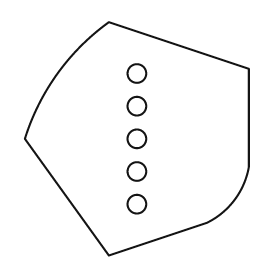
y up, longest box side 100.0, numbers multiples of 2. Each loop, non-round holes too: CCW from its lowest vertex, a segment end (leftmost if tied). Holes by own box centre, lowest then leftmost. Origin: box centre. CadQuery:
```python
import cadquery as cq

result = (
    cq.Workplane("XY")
    .moveTo(-12.0, -50.0)
    .lineTo(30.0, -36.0)
    .threePointArc((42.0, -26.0), (48.0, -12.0))
    .lineTo(48.0, 30.0)
    .lineTo(-12.0, 50.0)
    .threePointArc((-34.0, 28.0), (-48.0, 0.0))
    .close()
    .moveTo(0.0, -28.0)
    .circle(4.0)
    .moveTo(0.0, -14.0)
    .circle(4.0)
    .moveTo(0.0, 0.0)
    .circle(4.0)
    .moveTo(0.0, 14.0)
    .circle(4.0)
    .moveTo(0.0, 28.0)
    .circle(4.0)
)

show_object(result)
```